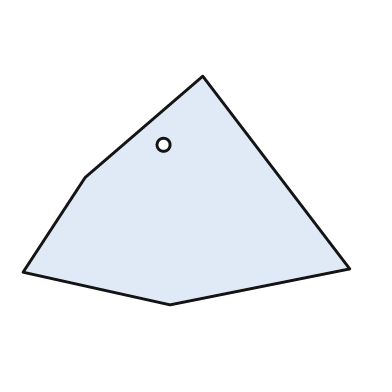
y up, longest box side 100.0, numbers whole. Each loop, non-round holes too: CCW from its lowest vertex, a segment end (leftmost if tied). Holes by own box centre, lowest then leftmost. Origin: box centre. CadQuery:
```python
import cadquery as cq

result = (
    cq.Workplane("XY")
    .moveTo(-5.0, -35.0)
    .lineTo(50.0, -24.0)
    .lineTo(5.0, 35.0)
    .lineTo(-31.0, 4.0)
    .lineTo(-50.0, -25.0)
    .close()
    .moveTo(-7.0, 14.0)
    .circle(2.0)
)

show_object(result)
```